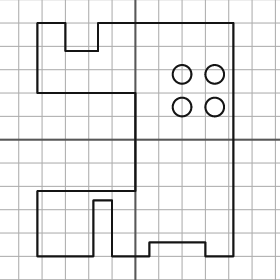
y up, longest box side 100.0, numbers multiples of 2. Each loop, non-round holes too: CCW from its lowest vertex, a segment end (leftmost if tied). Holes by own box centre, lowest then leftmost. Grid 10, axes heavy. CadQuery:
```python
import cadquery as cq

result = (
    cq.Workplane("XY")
    .moveTo(-42.0, -50.0)
    .lineTo(-18.0, -50.0)
    .lineTo(-18.0, -26.0)
    .lineTo(-10.0, -26.0)
    .lineTo(-10.0, -50.0)
    .lineTo(6.0, -50.0)
    .lineTo(6.0, -44.0)
    .lineTo(30.0, -44.0)
    .lineTo(30.0, -50.0)
    .lineTo(42.0, -50.0)
    .lineTo(42.0, 50.0)
    .lineTo(-16.0, 50.0)
    .lineTo(-16.0, 38.0)
    .lineTo(-30.0, 38.0)
    .lineTo(-30.0, 50.0)
    .lineTo(-42.0, 50.0)
    .lineTo(-42.0, 20.0)
    .lineTo(0.0, 20.0)
    .lineTo(0.0, -22.0)
    .lineTo(-42.0, -22.0)
    .close()
    .moveTo(20.0, 14.0)
    .circle(4.0)
    .moveTo(34.0, 14.0)
    .circle(4.0)
    .moveTo(20.0, 28.0)
    .circle(4.0)
    .moveTo(34.0, 28.0)
    .circle(4.0)
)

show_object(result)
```